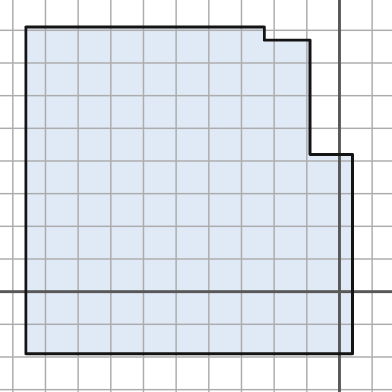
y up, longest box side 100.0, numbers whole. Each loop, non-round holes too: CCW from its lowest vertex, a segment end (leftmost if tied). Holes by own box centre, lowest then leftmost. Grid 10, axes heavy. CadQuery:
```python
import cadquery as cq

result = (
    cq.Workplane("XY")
    .moveTo(-96.0, -19.0)
    .lineTo(4.0, -19.0)
    .lineTo(4.0, 42.0)
    .lineTo(-9.0, 42.0)
    .lineTo(-9.0, 77.0)
    .lineTo(-23.0, 77.0)
    .lineTo(-23.0, 81.0)
    .lineTo(-96.0, 81.0)
    .close()
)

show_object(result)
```